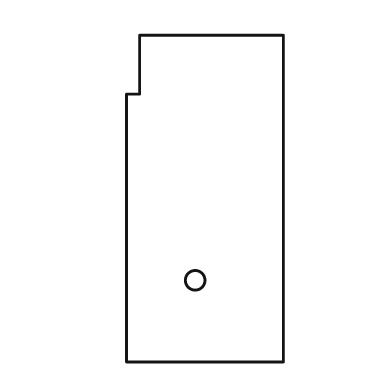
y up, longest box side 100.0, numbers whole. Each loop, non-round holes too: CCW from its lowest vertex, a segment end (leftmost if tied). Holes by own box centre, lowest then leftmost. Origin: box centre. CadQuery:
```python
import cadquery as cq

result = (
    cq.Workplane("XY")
    .moveTo(-24.0, -50.0)
    .lineTo(24.0, -50.0)
    .lineTo(24.0, 50.0)
    .lineTo(-20.0, 50.0)
    .lineTo(-20.0, 32.0)
    .lineTo(-24.0, 32.0)
    .close()
    .moveTo(-3.0, -25.0)
    .circle(3.0)
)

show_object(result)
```